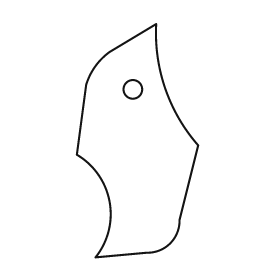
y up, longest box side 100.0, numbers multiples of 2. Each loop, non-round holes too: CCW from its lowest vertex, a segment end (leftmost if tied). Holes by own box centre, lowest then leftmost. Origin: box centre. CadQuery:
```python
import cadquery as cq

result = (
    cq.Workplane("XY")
    .moveTo(-18.0, -50.0)
    .lineTo(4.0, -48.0)
    .threePointArc((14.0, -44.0), (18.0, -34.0))
    .lineTo(26.0, -2.0)
    .threePointArc((12.0, 22.0), (8.0, 50.0))
    .lineTo(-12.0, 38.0)
    .threePointArc((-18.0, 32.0), (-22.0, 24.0))
    .lineTo(-26.0, -6.0)
    .threePointArc((-12.0, -26.0), (-18.0, -50.0))
    .close()
    .moveTo(-2.0, 22.0)
    .circle(4.0)
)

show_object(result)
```